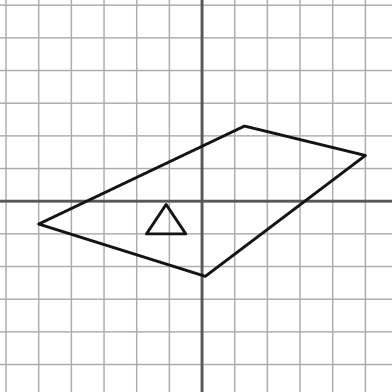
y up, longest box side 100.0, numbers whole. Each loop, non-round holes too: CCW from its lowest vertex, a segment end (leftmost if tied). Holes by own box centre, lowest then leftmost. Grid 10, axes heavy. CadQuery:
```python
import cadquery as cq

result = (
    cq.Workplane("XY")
    .moveTo(1.0, -23.0)
    .lineTo(50.0, 14.0)
    .lineTo(13.0, 23.0)
    .lineTo(-50.0, -7.0)
    .close()
    .moveTo(-17.0, -10.0)
    .lineTo(-5.0, -10.0)
    .lineTo(-11.0, -1.0)
    .close()
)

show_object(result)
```